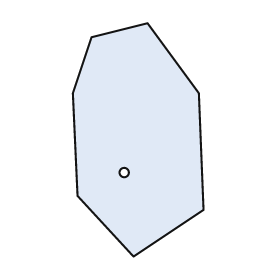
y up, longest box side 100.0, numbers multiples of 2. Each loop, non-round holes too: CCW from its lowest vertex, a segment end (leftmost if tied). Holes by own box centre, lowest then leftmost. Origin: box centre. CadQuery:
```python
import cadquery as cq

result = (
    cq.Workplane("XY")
    .moveTo(-2.0, -50.0)
    .lineTo(28.0, -30.0)
    .lineTo(26.0, 20.0)
    .lineTo(4.0, 50.0)
    .lineTo(-20.0, 44.0)
    .lineTo(-28.0, 20.0)
    .lineTo(-26.0, -24.0)
    .close()
    .moveTo(-6.0, -14.0)
    .circle(2.0)
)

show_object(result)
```